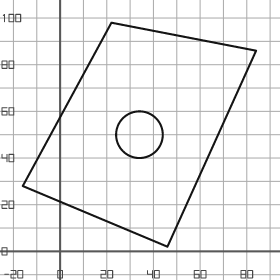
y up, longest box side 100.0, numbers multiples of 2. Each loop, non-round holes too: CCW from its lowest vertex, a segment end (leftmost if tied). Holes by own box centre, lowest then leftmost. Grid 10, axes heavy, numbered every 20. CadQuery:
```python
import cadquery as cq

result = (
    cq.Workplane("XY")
    .moveTo(46.0, 2.0)
    .lineTo(84.0, 86.0)
    .lineTo(22.0, 98.0)
    .lineTo(-16.0, 28.0)
    .close()
    .moveTo(34.0, 50.0)
    .circle(10.0)
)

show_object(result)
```